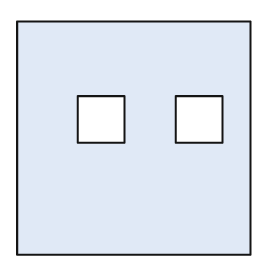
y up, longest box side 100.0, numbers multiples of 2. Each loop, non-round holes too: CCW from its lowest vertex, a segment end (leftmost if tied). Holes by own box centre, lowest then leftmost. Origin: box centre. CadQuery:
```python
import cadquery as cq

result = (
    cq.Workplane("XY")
    .moveTo(-50.0, -50.0)
    .lineTo(50.0, -50.0)
    .lineTo(50.0, 50.0)
    .lineTo(-50.0, 50.0)
    .close()
    .moveTo(-24.0, -2.0)
    .lineTo(-4.0, -2.0)
    .lineTo(-4.0, 18.0)
    .lineTo(-24.0, 18.0)
    .close()
    .moveTo(18.0, -2.0)
    .lineTo(38.0, -2.0)
    .lineTo(38.0, 18.0)
    .lineTo(18.0, 18.0)
    .close()
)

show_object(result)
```